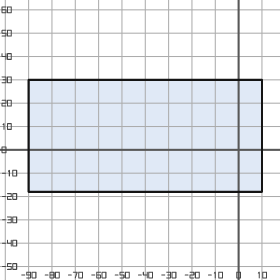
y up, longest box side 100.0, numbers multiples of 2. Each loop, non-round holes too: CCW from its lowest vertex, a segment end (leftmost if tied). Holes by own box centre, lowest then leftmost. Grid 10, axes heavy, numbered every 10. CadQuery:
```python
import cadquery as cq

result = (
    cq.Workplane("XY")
    .moveTo(-90.0, -18.0)
    .lineTo(10.0, -18.0)
    .lineTo(10.0, 30.0)
    .lineTo(-90.0, 30.0)
    .close()
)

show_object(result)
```